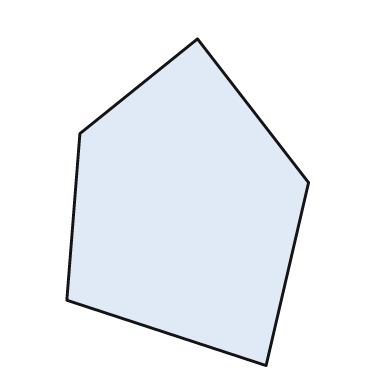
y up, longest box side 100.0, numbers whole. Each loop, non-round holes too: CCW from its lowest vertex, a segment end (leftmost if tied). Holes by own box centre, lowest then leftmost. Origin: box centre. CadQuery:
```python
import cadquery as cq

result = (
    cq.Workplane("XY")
    .moveTo(24.0, -50.0)
    .lineTo(37.0, 6.0)
    .lineTo(3.0, 50.0)
    .lineTo(-33.0, 21.0)
    .lineTo(-37.0, -30.0)
    .close()
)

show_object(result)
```